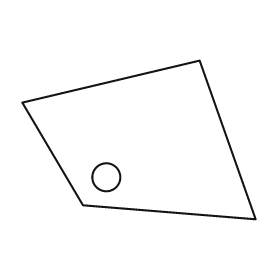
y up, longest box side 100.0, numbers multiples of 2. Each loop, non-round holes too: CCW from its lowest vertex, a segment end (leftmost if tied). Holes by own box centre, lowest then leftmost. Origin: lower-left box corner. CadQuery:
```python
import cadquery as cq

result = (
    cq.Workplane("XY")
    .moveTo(100.0, 0.0)
    .lineTo(76.0, 68.0)
    .lineTo(0.0, 50.0)
    .lineTo(26.0, 6.0)
    .close()
    .moveTo(36.0, 18.0)
    .circle(6.0)
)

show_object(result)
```